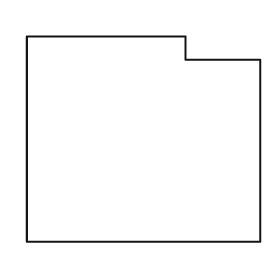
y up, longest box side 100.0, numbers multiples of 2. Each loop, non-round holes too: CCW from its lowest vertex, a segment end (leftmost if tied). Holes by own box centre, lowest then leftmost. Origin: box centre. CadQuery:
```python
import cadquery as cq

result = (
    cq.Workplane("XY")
    .moveTo(-50.0, -44.0)
    .lineTo(50.0, -44.0)
    .lineTo(50.0, 34.0)
    .lineTo(18.0, 34.0)
    .lineTo(18.0, 44.0)
    .lineTo(-50.0, 44.0)
    .close()
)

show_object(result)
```